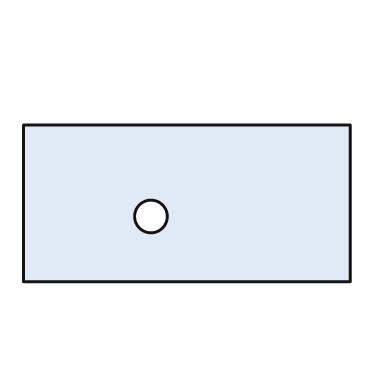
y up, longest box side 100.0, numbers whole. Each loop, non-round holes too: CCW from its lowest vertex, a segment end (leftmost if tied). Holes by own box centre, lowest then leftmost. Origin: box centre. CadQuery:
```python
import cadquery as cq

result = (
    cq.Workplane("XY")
    .moveTo(-50.0, -24.0)
    .lineTo(50.0, -24.0)
    .lineTo(50.0, 24.0)
    .lineTo(-50.0, 24.0)
    .close()
    .moveTo(-11.0, -4.0)
    .circle(5.0)
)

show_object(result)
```